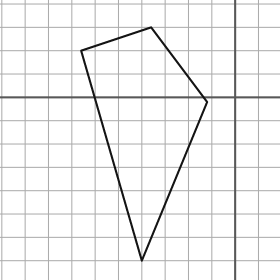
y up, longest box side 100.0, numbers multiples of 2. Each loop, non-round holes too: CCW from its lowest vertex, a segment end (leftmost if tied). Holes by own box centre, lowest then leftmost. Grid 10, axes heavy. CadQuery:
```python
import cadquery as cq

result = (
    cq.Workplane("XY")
    .moveTo(-40.0, -70.0)
    .lineTo(-12.0, -2.0)
    .lineTo(-36.0, 30.0)
    .lineTo(-66.0, 20.0)
    .close()
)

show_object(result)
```